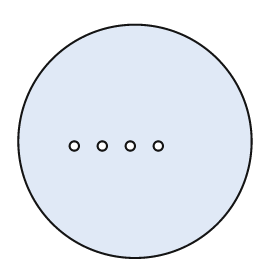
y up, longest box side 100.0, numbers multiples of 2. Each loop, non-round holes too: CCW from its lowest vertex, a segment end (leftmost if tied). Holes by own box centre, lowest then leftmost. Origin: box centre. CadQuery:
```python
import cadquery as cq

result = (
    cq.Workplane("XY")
    .moveTo(0.0, 0.0)
    .circle(50.0)
    .moveTo(-26.0, -2.0)
    .circle(2.0)
    .moveTo(-14.0, -2.0)
    .circle(2.0)
    .moveTo(-2.0, -2.0)
    .circle(2.0)
    .moveTo(10.0, -2.0)
    .circle(2.0)
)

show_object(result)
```